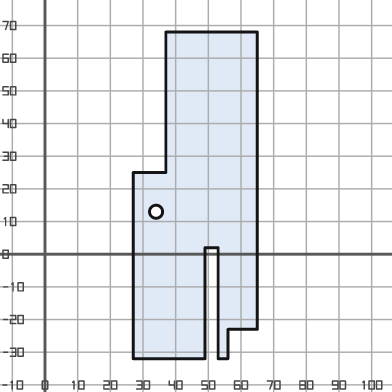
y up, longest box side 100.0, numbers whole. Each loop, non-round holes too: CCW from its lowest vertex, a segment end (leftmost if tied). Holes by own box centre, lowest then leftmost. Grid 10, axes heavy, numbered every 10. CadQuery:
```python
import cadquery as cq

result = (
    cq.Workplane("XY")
    .moveTo(27.0, -32.0)
    .lineTo(49.0, -32.0)
    .lineTo(49.0, 2.0)
    .lineTo(53.0, 2.0)
    .lineTo(53.0, -32.0)
    .lineTo(56.0, -32.0)
    .lineTo(56.0, -23.0)
    .lineTo(65.0, -23.0)
    .lineTo(65.0, 68.0)
    .lineTo(37.0, 68.0)
    .lineTo(37.0, 25.0)
    .lineTo(27.0, 25.0)
    .close()
    .moveTo(34.0, 13.0)
    .circle(2.0)
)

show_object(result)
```